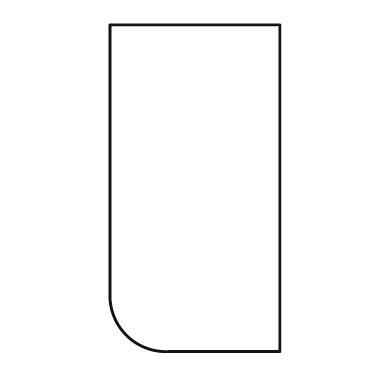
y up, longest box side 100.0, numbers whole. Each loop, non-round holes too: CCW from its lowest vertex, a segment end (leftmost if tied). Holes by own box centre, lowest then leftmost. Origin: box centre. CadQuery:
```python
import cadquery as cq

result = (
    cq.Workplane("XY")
    .moveTo(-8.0, -50.0)
    .lineTo(26.0, -50.0)
    .lineTo(26.0, 50.0)
    .lineTo(-26.0, 50.0)
    .lineTo(-26.0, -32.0)
    .threePointArc((-21.0, -45.0), (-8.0, -50.0))
    .close()
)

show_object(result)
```